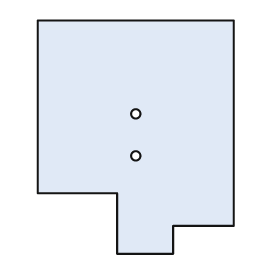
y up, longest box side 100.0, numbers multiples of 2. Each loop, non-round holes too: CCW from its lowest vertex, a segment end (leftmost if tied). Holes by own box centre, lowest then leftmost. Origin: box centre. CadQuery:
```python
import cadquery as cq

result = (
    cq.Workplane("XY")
    .moveTo(-8.0, -50.0)
    .lineTo(16.0, -50.0)
    .lineTo(16.0, -38.0)
    .lineTo(42.0, -38.0)
    .lineTo(42.0, 50.0)
    .lineTo(-42.0, 50.0)
    .lineTo(-42.0, -24.0)
    .lineTo(-8.0, -24.0)
    .close()
    .moveTo(0.0, -8.0)
    .circle(2.0)
    .moveTo(0.0, 10.0)
    .circle(2.0)
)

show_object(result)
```